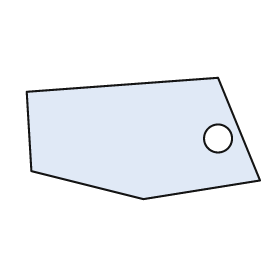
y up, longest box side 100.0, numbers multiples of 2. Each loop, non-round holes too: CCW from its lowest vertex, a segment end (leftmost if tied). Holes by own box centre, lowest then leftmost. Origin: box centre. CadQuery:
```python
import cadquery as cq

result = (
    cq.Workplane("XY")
    .moveTo(0.0, -26.0)
    .lineTo(50.0, -18.0)
    .lineTo(32.0, 26.0)
    .lineTo(-50.0, 20.0)
    .lineTo(-48.0, -14.0)
    .close()
    .moveTo(32.0, 0.0)
    .circle(6.0)
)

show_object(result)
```